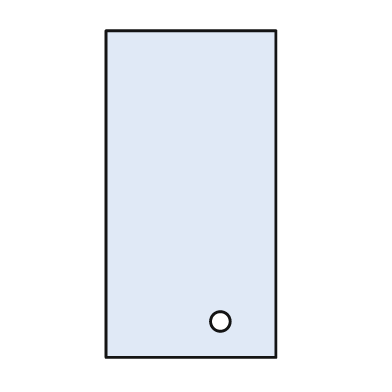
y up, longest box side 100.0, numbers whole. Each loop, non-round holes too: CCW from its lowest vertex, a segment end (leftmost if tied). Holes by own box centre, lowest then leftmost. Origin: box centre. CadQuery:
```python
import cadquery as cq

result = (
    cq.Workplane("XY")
    .moveTo(-26.0, -50.0)
    .lineTo(26.0, -50.0)
    .lineTo(26.0, 50.0)
    .lineTo(-26.0, 50.0)
    .close()
    .moveTo(9.0, -39.0)
    .circle(3.0)
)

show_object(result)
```